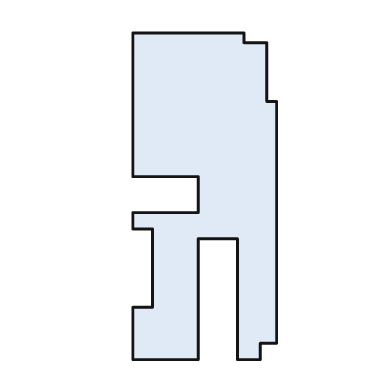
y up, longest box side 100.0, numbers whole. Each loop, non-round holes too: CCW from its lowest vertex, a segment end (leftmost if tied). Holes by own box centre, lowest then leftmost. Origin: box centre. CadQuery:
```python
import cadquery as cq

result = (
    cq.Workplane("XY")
    .moveTo(-22.0, -50.0)
    .lineTo(-2.0, -50.0)
    .lineTo(-2.0, -13.0)
    .lineTo(10.0, -13.0)
    .lineTo(10.0, -50.0)
    .lineTo(17.0, -50.0)
    .lineTo(17.0, -45.0)
    .lineTo(22.0, -45.0)
    .lineTo(22.0, 29.0)
    .lineTo(19.0, 29.0)
    .lineTo(19.0, 47.0)
    .lineTo(12.0, 47.0)
    .lineTo(12.0, 50.0)
    .lineTo(-22.0, 50.0)
    .lineTo(-22.0, 6.0)
    .lineTo(-2.0, 6.0)
    .lineTo(-2.0, -5.0)
    .lineTo(-22.0, -5.0)
    .lineTo(-22.0, -10.0)
    .lineTo(-16.0, -10.0)
    .lineTo(-16.0, -34.0)
    .lineTo(-22.0, -34.0)
    .close()
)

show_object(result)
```